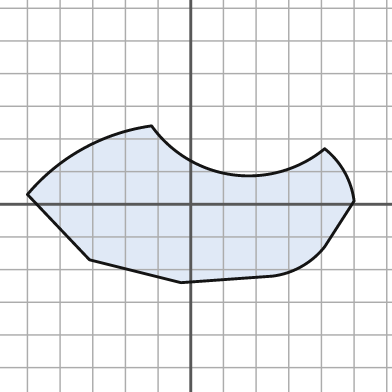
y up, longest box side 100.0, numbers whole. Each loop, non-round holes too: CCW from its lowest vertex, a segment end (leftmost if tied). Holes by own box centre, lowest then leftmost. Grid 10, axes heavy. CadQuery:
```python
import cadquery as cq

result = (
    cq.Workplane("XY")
    .moveTo(-3.0, -24.0)
    .lineTo(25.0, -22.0)
    .threePointArc((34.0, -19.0), (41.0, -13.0))
    .lineTo(50.0, 1.0)
    .threePointArc((47.0, 10.0), (41.0, 17.0))
    .threePointArc((13.0, 9.0), (-12.0, 24.0))
    .threePointArc((-33.0, 17.0), (-50.0, 3.0))
    .lineTo(-31.0, -17.0)
    .close()
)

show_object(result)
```